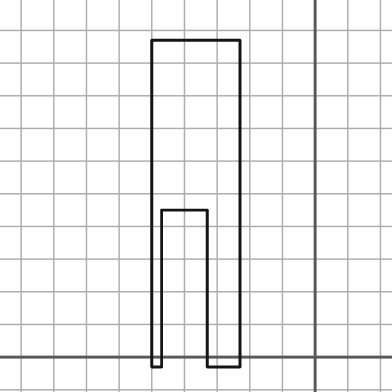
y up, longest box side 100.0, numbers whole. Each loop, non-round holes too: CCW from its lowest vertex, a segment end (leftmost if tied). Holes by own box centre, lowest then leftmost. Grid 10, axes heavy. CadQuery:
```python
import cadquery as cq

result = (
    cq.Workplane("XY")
    .moveTo(-50.0, -3.0)
    .lineTo(-47.0, -3.0)
    .lineTo(-47.0, 45.0)
    .lineTo(-33.0, 45.0)
    .lineTo(-33.0, -3.0)
    .lineTo(-23.0, -3.0)
    .lineTo(-23.0, 97.0)
    .lineTo(-50.0, 97.0)
    .close()
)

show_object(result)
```